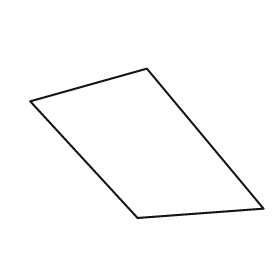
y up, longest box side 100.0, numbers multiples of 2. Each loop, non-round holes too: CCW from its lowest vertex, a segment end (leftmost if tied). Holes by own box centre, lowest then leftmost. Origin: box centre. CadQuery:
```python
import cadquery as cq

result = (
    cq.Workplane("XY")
    .moveTo(-4.0, -32.0)
    .lineTo(50.0, -28.0)
    .lineTo(0.0, 32.0)
    .lineTo(-50.0, 18.0)
    .close()
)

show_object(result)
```